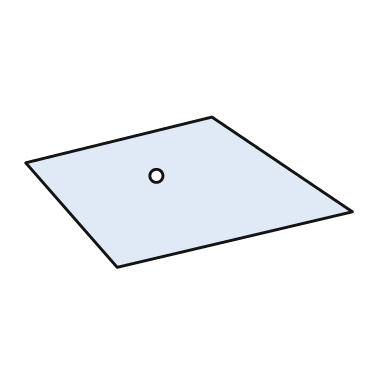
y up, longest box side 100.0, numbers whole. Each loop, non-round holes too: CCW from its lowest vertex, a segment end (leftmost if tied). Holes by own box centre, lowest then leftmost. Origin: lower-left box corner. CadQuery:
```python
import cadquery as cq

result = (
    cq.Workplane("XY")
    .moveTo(28.0, 0.0)
    .lineTo(100.0, 17.0)
    .lineTo(57.0, 46.0)
    .lineTo(0.0, 32.0)
    .close()
    .moveTo(40.0, 28.0)
    .circle(2.0)
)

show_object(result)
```